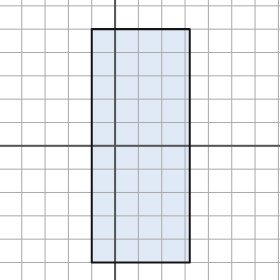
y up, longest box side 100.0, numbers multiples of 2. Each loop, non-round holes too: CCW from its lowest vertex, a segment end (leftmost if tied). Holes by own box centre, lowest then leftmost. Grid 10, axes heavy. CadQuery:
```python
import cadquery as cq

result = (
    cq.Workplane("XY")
    .moveTo(-10.0, -50.0)
    .lineTo(32.0, -50.0)
    .lineTo(32.0, 50.0)
    .lineTo(-10.0, 50.0)
    .close()
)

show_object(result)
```